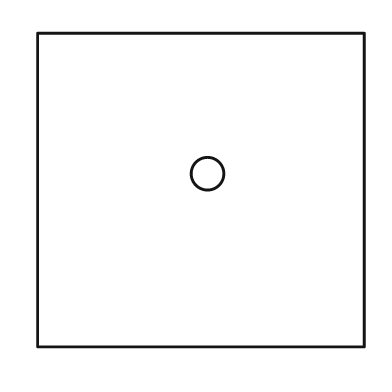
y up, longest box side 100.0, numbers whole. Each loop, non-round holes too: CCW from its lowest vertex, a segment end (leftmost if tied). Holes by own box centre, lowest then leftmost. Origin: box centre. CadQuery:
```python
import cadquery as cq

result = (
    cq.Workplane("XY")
    .moveTo(-50.0, -48.0)
    .lineTo(50.0, -48.0)
    .lineTo(50.0, 48.0)
    .lineTo(-50.0, 48.0)
    .close()
    .moveTo(2.0, 5.0)
    .circle(5.0)
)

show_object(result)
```